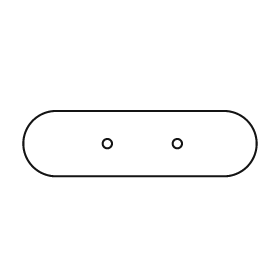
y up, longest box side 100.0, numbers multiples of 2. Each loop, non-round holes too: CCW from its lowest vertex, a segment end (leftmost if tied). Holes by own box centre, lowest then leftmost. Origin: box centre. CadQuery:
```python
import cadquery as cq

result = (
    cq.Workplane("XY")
    .moveTo(-36.0, -14.0)
    .lineTo(36.0, -14.0)
    .threePointArc((50.0, 0.0), (36.0, 14.0))
    .lineTo(-36.0, 14.0)
    .threePointArc((-50.0, 0.0), (-36.0, -14.0))
    .close()
    .moveTo(-14.0, 0.0)
    .circle(2.0)
    .moveTo(16.0, 0.0)
    .circle(2.0)
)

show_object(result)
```